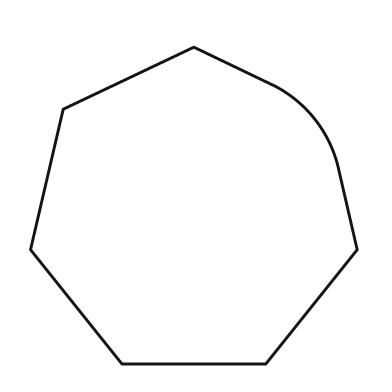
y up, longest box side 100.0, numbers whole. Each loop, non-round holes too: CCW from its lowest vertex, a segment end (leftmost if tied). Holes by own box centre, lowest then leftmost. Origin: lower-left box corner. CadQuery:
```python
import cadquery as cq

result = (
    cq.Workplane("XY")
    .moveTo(28.0, 0.0)
    .lineTo(72.0, 0.0)
    .lineTo(100.0, 35.0)
    .lineTo(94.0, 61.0)
    .threePointArc((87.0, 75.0), (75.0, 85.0))
    .lineTo(50.0, 97.0)
    .lineTo(10.0, 78.0)
    .lineTo(0.0, 35.0)
    .close()
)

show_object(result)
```